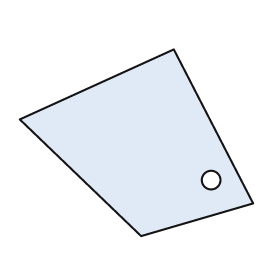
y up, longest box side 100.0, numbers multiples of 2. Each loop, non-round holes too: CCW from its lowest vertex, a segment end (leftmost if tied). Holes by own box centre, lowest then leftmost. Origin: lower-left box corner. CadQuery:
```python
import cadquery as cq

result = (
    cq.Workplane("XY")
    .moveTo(52.0, 0.0)
    .lineTo(100.0, 14.0)
    .lineTo(66.0, 80.0)
    .lineTo(0.0, 50.0)
    .close()
    .moveTo(82.0, 24.0)
    .circle(4.0)
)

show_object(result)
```